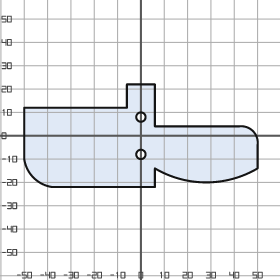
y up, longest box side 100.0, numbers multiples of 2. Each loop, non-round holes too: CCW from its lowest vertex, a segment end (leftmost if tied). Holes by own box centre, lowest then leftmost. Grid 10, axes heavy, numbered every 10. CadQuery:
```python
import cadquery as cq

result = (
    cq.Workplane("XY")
    .moveTo(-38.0, -22.0)
    .lineTo(6.0, -22.0)
    .lineTo(6.0, -14.0)
    .threePointArc((28.0, -20.0), (50.0, -14.0))
    .lineTo(50.0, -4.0)
    .threePointArc((48.0, 2.0), (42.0, 4.0))
    .lineTo(6.0, 4.0)
    .lineTo(6.0, 22.0)
    .lineTo(-6.0, 22.0)
    .lineTo(-6.0, 12.0)
    .lineTo(-50.0, 12.0)
    .lineTo(-50.0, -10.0)
    .threePointArc((-46.0, -18.0), (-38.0, -22.0))
    .close()
    .moveTo(0.0, -8.0)
    .circle(2.0)
    .moveTo(0.0, 8.0)
    .circle(2.0)
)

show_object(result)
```